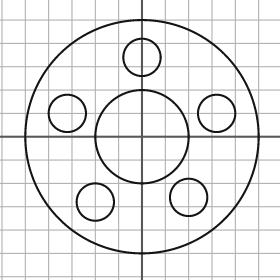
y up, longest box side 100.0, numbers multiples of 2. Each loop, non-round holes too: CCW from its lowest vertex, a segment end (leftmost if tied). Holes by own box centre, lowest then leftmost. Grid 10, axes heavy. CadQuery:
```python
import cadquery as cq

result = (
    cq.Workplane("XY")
    .moveTo(0.0, 0.0)
    .circle(50.0)
    .moveTo(-20.0, -28.0)
    .circle(8.0)
    .moveTo(20.0, -26.0)
    .circle(8.0)
    .moveTo(0.0, 0.0)
    .circle(20.0)
    .moveTo(-32.0, 10.0)
    .circle(8.0)
    .moveTo(32.0, 10.0)
    .circle(8.0)
    .moveTo(0.0, 34.0)
    .circle(8.0)
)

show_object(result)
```